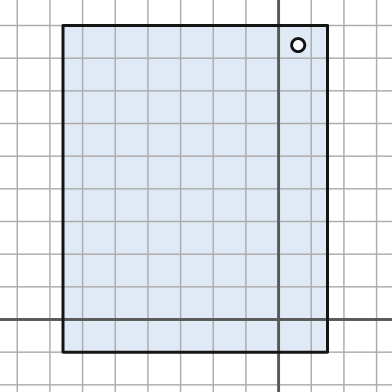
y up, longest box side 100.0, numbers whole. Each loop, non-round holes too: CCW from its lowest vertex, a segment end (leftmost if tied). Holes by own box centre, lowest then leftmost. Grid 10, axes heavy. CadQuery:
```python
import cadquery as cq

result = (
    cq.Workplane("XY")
    .moveTo(-66.0, -10.0)
    .lineTo(15.0, -10.0)
    .lineTo(15.0, 90.0)
    .lineTo(-66.0, 90.0)
    .close()
    .moveTo(6.0, 84.0)
    .circle(2.0)
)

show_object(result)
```